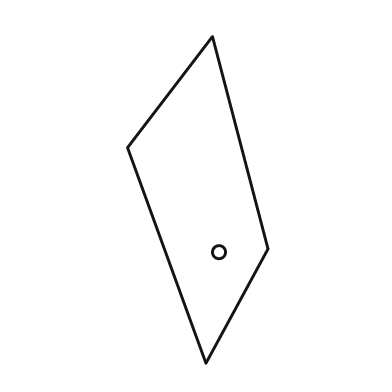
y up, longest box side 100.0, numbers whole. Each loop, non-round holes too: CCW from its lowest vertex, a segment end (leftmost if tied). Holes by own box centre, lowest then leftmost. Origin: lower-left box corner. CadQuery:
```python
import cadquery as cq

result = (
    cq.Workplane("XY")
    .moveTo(24.0, 0.0)
    .lineTo(43.0, 35.0)
    .lineTo(26.0, 100.0)
    .lineTo(0.0, 66.0)
    .close()
    .moveTo(28.0, 34.0)
    .circle(2.0)
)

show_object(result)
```